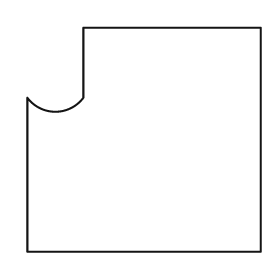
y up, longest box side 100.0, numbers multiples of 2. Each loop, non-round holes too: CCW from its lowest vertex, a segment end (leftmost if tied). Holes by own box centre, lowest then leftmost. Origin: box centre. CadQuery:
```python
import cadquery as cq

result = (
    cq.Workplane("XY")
    .moveTo(-50.0, -48.0)
    .lineTo(50.0, -48.0)
    .lineTo(50.0, 48.0)
    .lineTo(-26.0, 48.0)
    .lineTo(-26.0, 18.0)
    .threePointArc((-38.0, 12.0), (-50.0, 18.0))
    .close()
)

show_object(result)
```